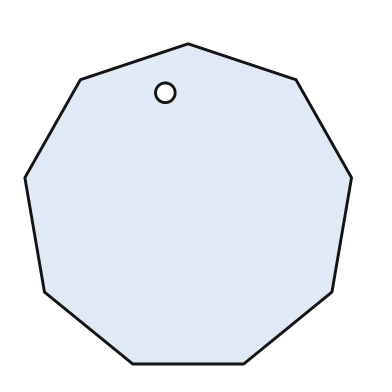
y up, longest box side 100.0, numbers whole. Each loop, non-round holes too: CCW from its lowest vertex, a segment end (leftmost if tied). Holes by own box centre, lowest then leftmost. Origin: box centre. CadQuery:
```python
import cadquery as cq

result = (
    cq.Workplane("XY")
    .moveTo(-17.0, -49.0)
    .lineTo(17.0, -49.0)
    .lineTo(44.0, -27.0)
    .lineTo(50.0, 8.0)
    .lineTo(33.0, 38.0)
    .lineTo(0.0, 49.0)
    .lineTo(-33.0, 38.0)
    .lineTo(-50.0, 8.0)
    .lineTo(-44.0, -27.0)
    .close()
    .moveTo(-7.0, 34.0)
    .circle(3.0)
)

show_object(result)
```